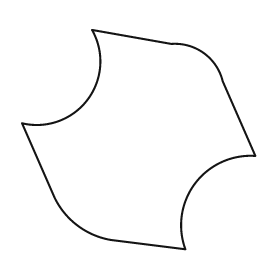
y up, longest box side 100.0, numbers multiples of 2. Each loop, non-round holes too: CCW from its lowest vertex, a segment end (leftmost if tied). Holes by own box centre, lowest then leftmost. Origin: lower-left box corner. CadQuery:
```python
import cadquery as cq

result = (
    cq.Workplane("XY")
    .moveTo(70.0, 0.0)
    .threePointArc((74.0, 28.0), (100.0, 40.0))
    .lineTo(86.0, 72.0)
    .threePointArc((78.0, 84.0), (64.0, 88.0))
    .lineTo(30.0, 94.0)
    .threePointArc((28.0, 64.0), (0.0, 54.0))
    .lineTo(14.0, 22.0)
    .threePointArc((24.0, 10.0), (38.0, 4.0))
    .close()
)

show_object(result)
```